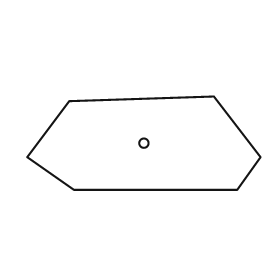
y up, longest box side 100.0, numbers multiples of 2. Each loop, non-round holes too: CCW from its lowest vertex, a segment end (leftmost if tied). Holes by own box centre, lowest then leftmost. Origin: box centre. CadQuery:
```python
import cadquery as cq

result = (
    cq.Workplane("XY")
    .moveTo(-30.0, -20.0)
    .lineTo(40.0, -20.0)
    .lineTo(50.0, -6.0)
    .lineTo(30.0, 20.0)
    .lineTo(-32.0, 18.0)
    .lineTo(-50.0, -6.0)
    .close()
    .moveTo(0.0, 0.0)
    .circle(2.0)
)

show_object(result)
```